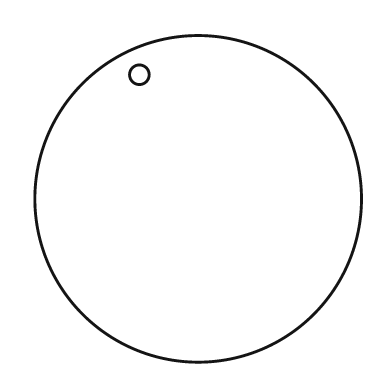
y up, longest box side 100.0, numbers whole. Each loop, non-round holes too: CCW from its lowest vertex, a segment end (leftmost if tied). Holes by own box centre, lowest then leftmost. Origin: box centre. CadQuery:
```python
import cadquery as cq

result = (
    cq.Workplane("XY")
    .moveTo(0.0, 0.0)
    .circle(50.0)
    .moveTo(-18.0, 38.0)
    .circle(3.0)
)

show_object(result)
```